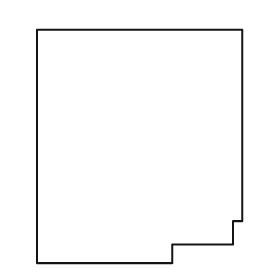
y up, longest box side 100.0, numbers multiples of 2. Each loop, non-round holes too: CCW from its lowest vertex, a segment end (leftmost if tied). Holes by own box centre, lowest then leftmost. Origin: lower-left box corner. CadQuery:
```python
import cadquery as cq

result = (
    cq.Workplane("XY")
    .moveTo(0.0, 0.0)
    .lineTo(58.0, 0.0)
    .lineTo(58.0, 8.0)
    .lineTo(84.0, 8.0)
    .lineTo(84.0, 18.0)
    .lineTo(88.0, 18.0)
    .lineTo(88.0, 100.0)
    .lineTo(0.0, 100.0)
    .close()
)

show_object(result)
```